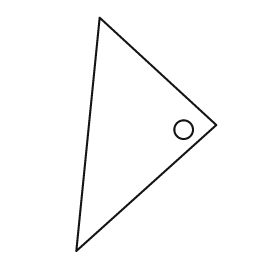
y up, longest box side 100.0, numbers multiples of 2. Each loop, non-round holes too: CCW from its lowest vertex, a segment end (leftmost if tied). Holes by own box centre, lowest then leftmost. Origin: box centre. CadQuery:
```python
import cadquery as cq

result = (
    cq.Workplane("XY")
    .moveTo(-30.0, -50.0)
    .lineTo(30.0, 4.0)
    .lineTo(-20.0, 50.0)
    .close()
    .moveTo(16.0, 2.0)
    .circle(4.0)
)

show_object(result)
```